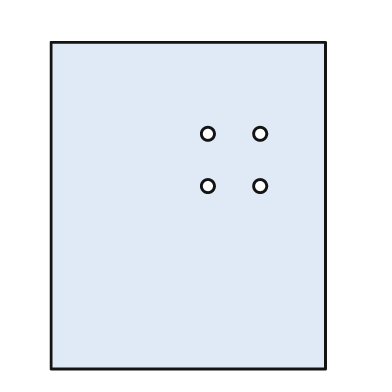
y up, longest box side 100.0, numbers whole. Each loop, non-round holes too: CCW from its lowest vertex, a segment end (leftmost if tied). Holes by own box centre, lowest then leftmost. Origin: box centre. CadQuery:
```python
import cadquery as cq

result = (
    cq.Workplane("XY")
    .moveTo(-42.0, -50.0)
    .lineTo(42.0, -50.0)
    .lineTo(42.0, 50.0)
    .lineTo(-42.0, 50.0)
    .close()
    .moveTo(6.0, 6.0)
    .circle(2.0)
    .moveTo(22.0, 6.0)
    .circle(2.0)
    .moveTo(6.0, 22.0)
    .circle(2.0)
    .moveTo(22.0, 22.0)
    .circle(2.0)
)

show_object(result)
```